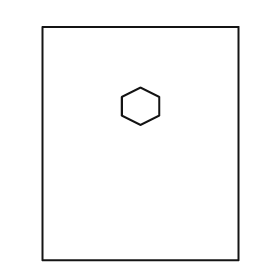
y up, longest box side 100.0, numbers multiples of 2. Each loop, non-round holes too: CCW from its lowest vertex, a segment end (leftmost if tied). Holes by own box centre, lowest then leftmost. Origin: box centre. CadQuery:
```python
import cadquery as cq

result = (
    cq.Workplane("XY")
    .moveTo(-42.0, -50.0)
    .lineTo(42.0, -50.0)
    .lineTo(42.0, 50.0)
    .lineTo(-42.0, 50.0)
    .close()
    .moveTo(0.0, 8.0)
    .lineTo(8.0, 12.0)
    .lineTo(8.0, 20.0)
    .lineTo(0.0, 24.0)
    .lineTo(-8.0, 20.0)
    .lineTo(-8.0, 12.0)
    .close()
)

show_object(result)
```